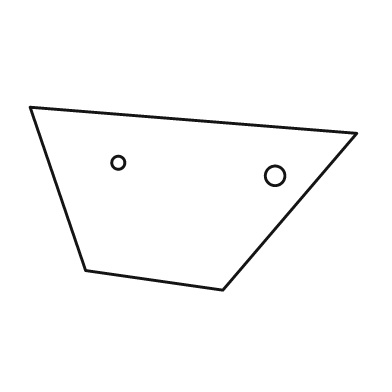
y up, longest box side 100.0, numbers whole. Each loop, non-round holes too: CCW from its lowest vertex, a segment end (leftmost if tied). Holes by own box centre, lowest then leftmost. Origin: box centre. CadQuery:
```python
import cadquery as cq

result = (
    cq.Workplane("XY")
    .moveTo(9.0, -28.0)
    .lineTo(50.0, 20.0)
    .lineTo(-50.0, 28.0)
    .lineTo(-33.0, -22.0)
    .close()
    .moveTo(25.0, 7.0)
    .circle(3.0)
    .moveTo(-23.0, 11.0)
    .circle(2.0)
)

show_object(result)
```